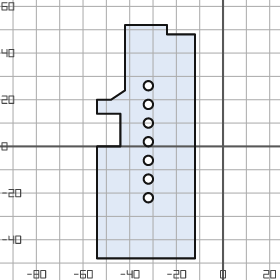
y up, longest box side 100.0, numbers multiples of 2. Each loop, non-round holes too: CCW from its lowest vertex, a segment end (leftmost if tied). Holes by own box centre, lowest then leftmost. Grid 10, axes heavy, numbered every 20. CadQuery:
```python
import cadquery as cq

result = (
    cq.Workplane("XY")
    .moveTo(-54.0, -48.0)
    .lineTo(-12.0, -48.0)
    .lineTo(-12.0, 48.0)
    .lineTo(-24.0, 48.0)
    .lineTo(-24.0, 52.0)
    .lineTo(-42.0, 52.0)
    .lineTo(-42.0, 24.0)
    .lineTo(-48.0, 20.0)
    .lineTo(-54.0, 20.0)
    .lineTo(-54.0, 14.0)
    .lineTo(-44.0, 14.0)
    .lineTo(-44.0, 0.0)
    .lineTo(-54.0, 0.0)
    .close()
    .moveTo(-32.0, -22.0)
    .circle(2.0)
    .moveTo(-32.0, -14.0)
    .circle(2.0)
    .moveTo(-32.0, -6.0)
    .circle(2.0)
    .moveTo(-32.0, 2.0)
    .circle(2.0)
    .moveTo(-32.0, 10.0)
    .circle(2.0)
    .moveTo(-32.0, 18.0)
    .circle(2.0)
    .moveTo(-32.0, 26.0)
    .circle(2.0)
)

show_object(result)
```